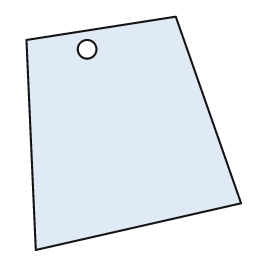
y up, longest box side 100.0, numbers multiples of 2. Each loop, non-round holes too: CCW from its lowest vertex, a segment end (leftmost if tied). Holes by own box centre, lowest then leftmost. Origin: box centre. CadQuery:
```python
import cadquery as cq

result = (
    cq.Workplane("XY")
    .moveTo(-42.0, -50.0)
    .lineTo(46.0, -30.0)
    .lineTo(18.0, 50.0)
    .lineTo(-46.0, 40.0)
    .close()
    .moveTo(-20.0, 36.0)
    .circle(4.0)
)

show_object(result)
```